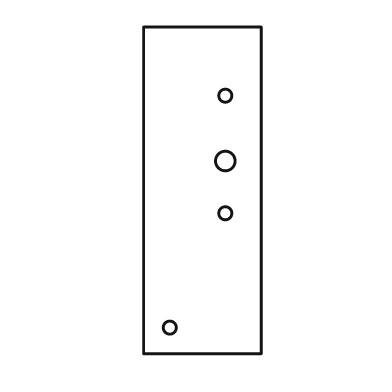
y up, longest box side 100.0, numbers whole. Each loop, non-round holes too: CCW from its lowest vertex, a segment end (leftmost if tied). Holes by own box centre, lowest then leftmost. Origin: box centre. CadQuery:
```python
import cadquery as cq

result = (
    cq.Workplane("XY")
    .moveTo(-18.0, -50.0)
    .lineTo(18.0, -50.0)
    .lineTo(18.0, 50.0)
    .lineTo(-18.0, 50.0)
    .close()
    .moveTo(-10.0, -42.0)
    .circle(2.0)
    .moveTo(7.0, -7.0)
    .circle(2.0)
    .moveTo(7.0, 9.0)
    .circle(3.0)
    .moveTo(7.0, 29.0)
    .circle(2.0)
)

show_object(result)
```